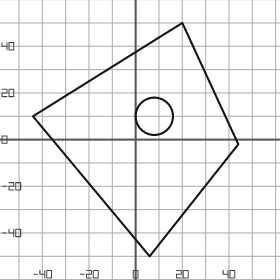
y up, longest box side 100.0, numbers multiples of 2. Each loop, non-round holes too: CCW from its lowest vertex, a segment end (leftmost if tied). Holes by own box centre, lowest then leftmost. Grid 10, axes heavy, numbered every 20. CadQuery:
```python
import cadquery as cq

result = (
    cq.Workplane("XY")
    .moveTo(6.0, -50.0)
    .lineTo(44.0, -2.0)
    .lineTo(20.0, 50.0)
    .lineTo(-44.0, 10.0)
    .close()
    .moveTo(8.0, 10.0)
    .circle(8.0)
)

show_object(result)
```